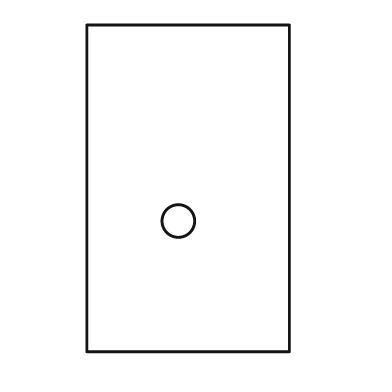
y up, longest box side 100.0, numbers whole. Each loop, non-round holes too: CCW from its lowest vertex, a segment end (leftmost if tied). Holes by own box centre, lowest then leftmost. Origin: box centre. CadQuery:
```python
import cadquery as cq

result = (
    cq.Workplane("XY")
    .moveTo(-31.0, -50.0)
    .lineTo(31.0, -50.0)
    .lineTo(31.0, 50.0)
    .lineTo(-31.0, 50.0)
    .close()
    .moveTo(-3.0, -10.0)
    .circle(5.0)
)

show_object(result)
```